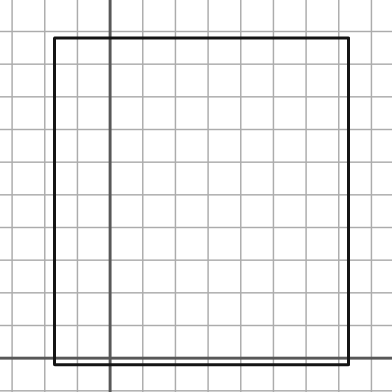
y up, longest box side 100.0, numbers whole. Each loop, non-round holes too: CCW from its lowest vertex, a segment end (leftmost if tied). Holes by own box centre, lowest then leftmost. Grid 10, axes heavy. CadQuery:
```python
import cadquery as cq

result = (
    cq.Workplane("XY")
    .moveTo(-17.0, -2.0)
    .lineTo(73.0, -2.0)
    .lineTo(73.0, 98.0)
    .lineTo(-17.0, 98.0)
    .close()
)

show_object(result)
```